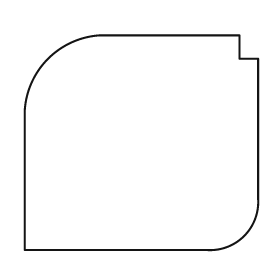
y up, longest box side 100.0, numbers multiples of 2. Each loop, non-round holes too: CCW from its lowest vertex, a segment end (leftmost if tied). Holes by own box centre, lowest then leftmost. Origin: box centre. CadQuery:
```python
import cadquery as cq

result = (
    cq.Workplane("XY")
    .moveTo(-50.0, -46.0)
    .lineTo(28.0, -46.0)
    .threePointArc((44.0, -40.0), (50.0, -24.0))
    .lineTo(50.0, 36.0)
    .lineTo(42.0, 36.0)
    .lineTo(42.0, 46.0)
    .lineTo(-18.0, 46.0)
    .threePointArc((-40.0, 36.0), (-50.0, 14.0))
    .close()
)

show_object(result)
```